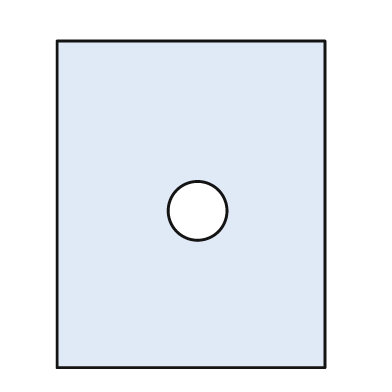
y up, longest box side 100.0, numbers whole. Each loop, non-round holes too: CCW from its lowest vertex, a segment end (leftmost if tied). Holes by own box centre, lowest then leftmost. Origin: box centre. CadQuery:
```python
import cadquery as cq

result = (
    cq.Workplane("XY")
    .moveTo(-41.0, -50.0)
    .lineTo(41.0, -50.0)
    .lineTo(41.0, 50.0)
    .lineTo(-41.0, 50.0)
    .close()
    .moveTo(2.0, -2.0)
    .circle(9.0)
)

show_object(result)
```